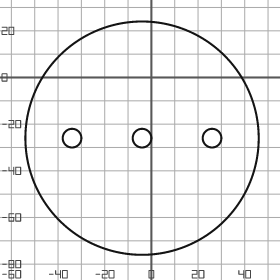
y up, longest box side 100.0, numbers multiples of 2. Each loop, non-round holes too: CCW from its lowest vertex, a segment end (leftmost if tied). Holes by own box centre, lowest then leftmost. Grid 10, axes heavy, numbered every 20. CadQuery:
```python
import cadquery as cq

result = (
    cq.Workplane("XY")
    .moveTo(-4.0, -26.0)
    .circle(50.0)
    .moveTo(-34.0, -26.0)
    .circle(4.0)
    .moveTo(-4.0, -26.0)
    .circle(4.0)
    .moveTo(26.0, -26.0)
    .circle(4.0)
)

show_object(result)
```